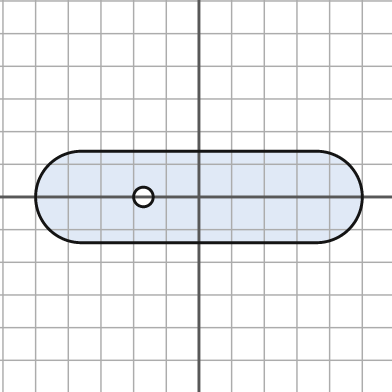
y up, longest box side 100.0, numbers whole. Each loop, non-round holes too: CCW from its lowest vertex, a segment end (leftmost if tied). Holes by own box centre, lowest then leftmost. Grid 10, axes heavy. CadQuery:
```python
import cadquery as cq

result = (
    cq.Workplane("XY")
    .moveTo(-36.0, -14.0)
    .lineTo(36.0, -14.0)
    .threePointArc((50.0, 0.0), (36.0, 14.0))
    .lineTo(-36.0, 14.0)
    .threePointArc((-50.0, 0.0), (-36.0, -14.0))
    .close()
    .moveTo(-17.0, 0.0)
    .circle(3.0)
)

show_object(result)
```